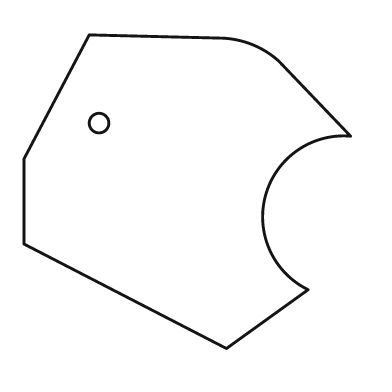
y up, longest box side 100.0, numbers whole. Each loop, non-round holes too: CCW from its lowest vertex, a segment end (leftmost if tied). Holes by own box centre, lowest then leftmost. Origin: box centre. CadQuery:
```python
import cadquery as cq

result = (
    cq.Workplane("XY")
    .moveTo(12.0, -48.0)
    .lineTo(37.0, -30.0)
    .threePointArc((24.0, -1.0), (50.0, 17.0))
    .lineTo(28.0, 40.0)
    .threePointArc((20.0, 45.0), (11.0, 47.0))
    .lineTo(-30.0, 48.0)
    .lineTo(-50.0, 10.0)
    .lineTo(-50.0, -16.0)
    .close()
    .moveTo(-27.0, 21.0)
    .circle(3.0)
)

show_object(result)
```